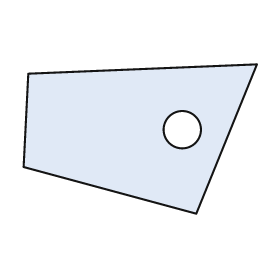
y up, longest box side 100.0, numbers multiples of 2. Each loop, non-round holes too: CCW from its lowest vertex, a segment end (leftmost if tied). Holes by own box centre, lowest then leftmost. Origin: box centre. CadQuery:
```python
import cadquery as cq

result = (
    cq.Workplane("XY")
    .moveTo(24.0, -32.0)
    .lineTo(50.0, 32.0)
    .lineTo(-48.0, 28.0)
    .lineTo(-50.0, -12.0)
    .close()
    .moveTo(18.0, 4.0)
    .circle(8.0)
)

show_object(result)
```